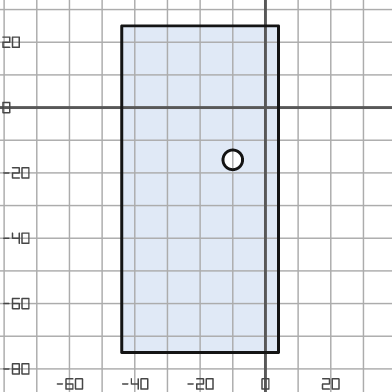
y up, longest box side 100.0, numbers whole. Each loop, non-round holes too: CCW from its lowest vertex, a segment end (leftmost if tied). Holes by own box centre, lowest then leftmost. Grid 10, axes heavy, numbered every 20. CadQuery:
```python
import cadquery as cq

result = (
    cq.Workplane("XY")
    .moveTo(-44.0, -75.0)
    .lineTo(4.0, -75.0)
    .lineTo(4.0, 25.0)
    .lineTo(-44.0, 25.0)
    .close()
    .moveTo(-10.0, -16.0)
    .circle(3.0)
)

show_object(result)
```